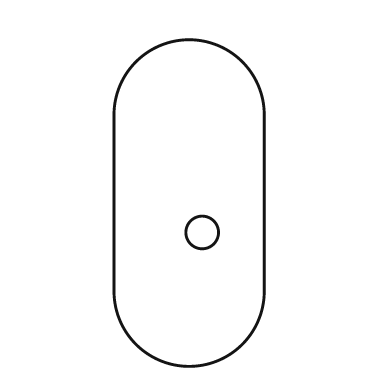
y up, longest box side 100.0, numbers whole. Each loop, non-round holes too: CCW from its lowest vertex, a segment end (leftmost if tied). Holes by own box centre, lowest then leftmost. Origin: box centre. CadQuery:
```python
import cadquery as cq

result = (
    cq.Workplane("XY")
    .moveTo(-23.0, -27.0)
    .threePointArc((0.0, -50.0), (23.0, -27.0))
    .lineTo(23.0, 27.0)
    .threePointArc((0.0, 50.0), (-23.0, 27.0))
    .close()
    .moveTo(4.0, -9.0)
    .circle(5.0)
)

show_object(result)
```